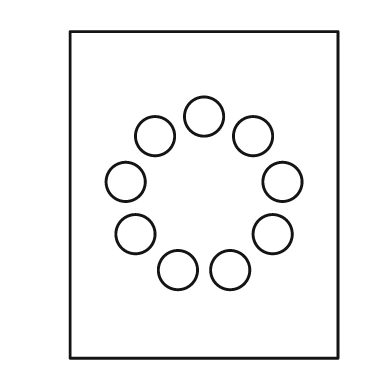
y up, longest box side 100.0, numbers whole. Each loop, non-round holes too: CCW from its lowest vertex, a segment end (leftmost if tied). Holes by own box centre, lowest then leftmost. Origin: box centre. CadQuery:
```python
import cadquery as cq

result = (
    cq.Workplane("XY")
    .moveTo(-41.0, -50.0)
    .lineTo(41.0, -50.0)
    .lineTo(41.0, 50.0)
    .lineTo(-41.0, 50.0)
    .close()
    .moveTo(-8.0, -23.0)
    .circle(6.0)
    .moveTo(8.0, -23.0)
    .circle(6.0)
    .moveTo(-21.0, -12.0)
    .circle(6.0)
    .moveTo(21.0, -12.0)
    .circle(6.0)
    .moveTo(-24.0, 4.0)
    .circle(6.0)
    .moveTo(24.0, 4.0)
    .circle(6.0)
    .moveTo(-15.0, 18.0)
    .circle(6.0)
    .moveTo(15.0, 18.0)
    .circle(6.0)
    .moveTo(0.0, 24.0)
    .circle(6.0)
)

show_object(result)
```